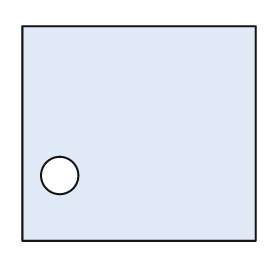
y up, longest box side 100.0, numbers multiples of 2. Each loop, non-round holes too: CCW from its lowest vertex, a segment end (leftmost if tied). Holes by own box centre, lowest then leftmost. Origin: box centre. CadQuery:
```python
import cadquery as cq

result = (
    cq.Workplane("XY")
    .moveTo(-50.0, -46.0)
    .lineTo(50.0, -46.0)
    .lineTo(50.0, 46.0)
    .lineTo(-50.0, 46.0)
    .close()
    .moveTo(-34.0, -18.0)
    .circle(8.0)
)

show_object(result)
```